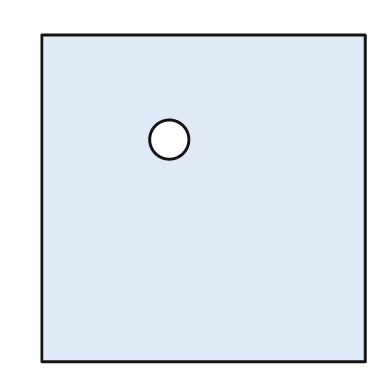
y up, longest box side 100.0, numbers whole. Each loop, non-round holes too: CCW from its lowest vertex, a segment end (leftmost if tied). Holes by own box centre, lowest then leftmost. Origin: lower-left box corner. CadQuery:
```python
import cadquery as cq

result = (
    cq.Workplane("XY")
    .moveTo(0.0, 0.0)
    .lineTo(99.0, 0.0)
    .lineTo(99.0, 100.0)
    .lineTo(0.0, 100.0)
    .close()
    .moveTo(39.0, 68.0)
    .circle(6.0)
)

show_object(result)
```